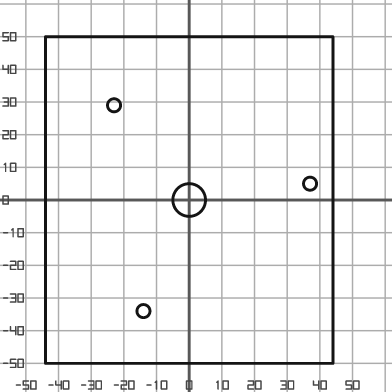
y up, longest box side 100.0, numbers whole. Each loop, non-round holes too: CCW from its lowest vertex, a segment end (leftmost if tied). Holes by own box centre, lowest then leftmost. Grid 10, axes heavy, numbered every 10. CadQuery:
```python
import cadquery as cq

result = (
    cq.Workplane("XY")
    .moveTo(-44.0, -50.0)
    .lineTo(44.0, -50.0)
    .lineTo(44.0, 50.0)
    .lineTo(-44.0, 50.0)
    .close()
    .moveTo(-14.0, -34.0)
    .circle(2.0)
    .moveTo(0.0, 0.0)
    .circle(5.0)
    .moveTo(37.0, 5.0)
    .circle(2.0)
    .moveTo(-23.0, 29.0)
    .circle(2.0)
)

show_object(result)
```